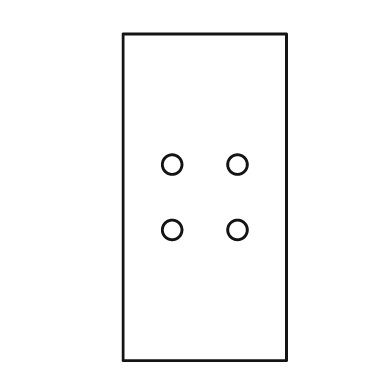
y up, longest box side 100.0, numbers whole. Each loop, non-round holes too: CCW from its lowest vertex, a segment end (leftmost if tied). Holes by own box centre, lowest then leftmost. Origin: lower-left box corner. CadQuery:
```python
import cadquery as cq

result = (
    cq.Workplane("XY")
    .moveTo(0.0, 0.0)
    .lineTo(50.0, 0.0)
    .lineTo(50.0, 100.0)
    .lineTo(0.0, 100.0)
    .close()
    .moveTo(15.0, 40.0)
    .circle(3.0)
    .moveTo(35.0, 40.0)
    .circle(3.0)
    .moveTo(15.0, 60.0)
    .circle(3.0)
    .moveTo(35.0, 60.0)
    .circle(3.0)
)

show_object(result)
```